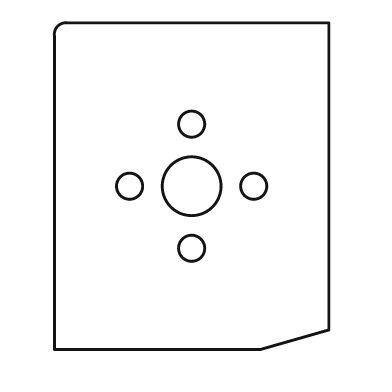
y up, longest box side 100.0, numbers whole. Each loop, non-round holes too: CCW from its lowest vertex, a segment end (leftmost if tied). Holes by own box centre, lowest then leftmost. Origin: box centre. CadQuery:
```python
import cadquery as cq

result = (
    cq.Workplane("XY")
    .moveTo(-42.0, -50.0)
    .lineTo(21.0, -50.0)
    .lineTo(42.0, -44.0)
    .lineTo(42.0, 50.0)
    .lineTo(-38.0, 50.0)
    .threePointArc((-41.0, 49.0), (-42.0, 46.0))
    .close()
    .moveTo(0.0, -19.0)
    .circle(4.0)
    .moveTo(-19.0, 0.0)
    .circle(4.0)
    .moveTo(0.0, 0.0)
    .circle(9.0)
    .moveTo(19.0, 0.0)
    .circle(4.0)
    .moveTo(0.0, 19.0)
    .circle(4.0)
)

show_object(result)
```